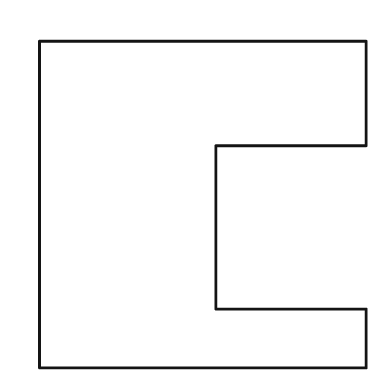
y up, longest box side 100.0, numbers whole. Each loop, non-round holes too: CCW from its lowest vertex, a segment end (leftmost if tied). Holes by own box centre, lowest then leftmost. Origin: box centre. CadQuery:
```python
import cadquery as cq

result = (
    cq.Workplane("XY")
    .moveTo(-50.0, -50.0)
    .lineTo(50.0, -50.0)
    .lineTo(50.0, -32.0)
    .lineTo(4.0, -32.0)
    .lineTo(4.0, 18.0)
    .lineTo(50.0, 18.0)
    .lineTo(50.0, 50.0)
    .lineTo(-50.0, 50.0)
    .close()
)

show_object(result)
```